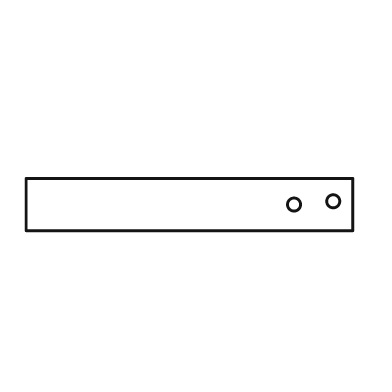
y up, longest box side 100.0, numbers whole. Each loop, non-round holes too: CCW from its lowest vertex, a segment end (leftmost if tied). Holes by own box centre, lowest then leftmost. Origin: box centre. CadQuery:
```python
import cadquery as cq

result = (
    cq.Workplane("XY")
    .moveTo(-50.0, -8.0)
    .lineTo(50.0, -8.0)
    .lineTo(50.0, 8.0)
    .lineTo(-50.0, 8.0)
    .close()
    .moveTo(32.0, 0.0)
    .circle(2.0)
    .moveTo(44.0, 1.0)
    .circle(2.0)
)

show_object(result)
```